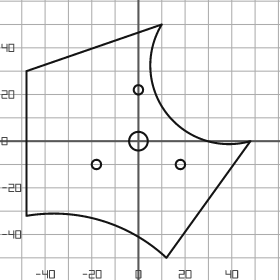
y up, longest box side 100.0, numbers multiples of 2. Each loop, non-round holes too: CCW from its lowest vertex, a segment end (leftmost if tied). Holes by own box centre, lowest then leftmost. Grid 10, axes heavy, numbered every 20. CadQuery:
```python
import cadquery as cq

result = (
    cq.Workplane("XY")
    .moveTo(12.0, -50.0)
    .lineTo(48.0, 0.0)
    .threePointArc((12.0, 12.0), (10.0, 50.0))
    .lineTo(-48.0, 30.0)
    .lineTo(-48.0, -32.0)
    .threePointArc((-16.0, -34.0), (12.0, -50.0))
    .close()
    .moveTo(-18.0, -10.0)
    .circle(2.0)
    .moveTo(18.0, -10.0)
    .circle(2.0)
    .moveTo(0.0, 0.0)
    .circle(4.0)
    .moveTo(0.0, 22.0)
    .circle(2.0)
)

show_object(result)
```